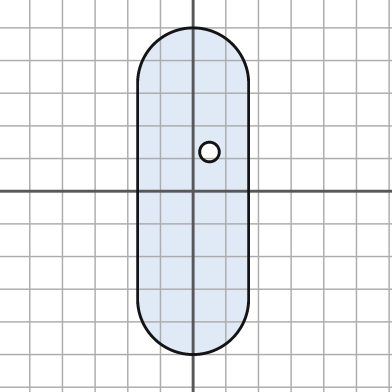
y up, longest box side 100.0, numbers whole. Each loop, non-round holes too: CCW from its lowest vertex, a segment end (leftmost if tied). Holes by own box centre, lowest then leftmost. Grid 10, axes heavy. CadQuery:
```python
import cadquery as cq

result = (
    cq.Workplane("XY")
    .moveTo(-17.0, -33.0)
    .threePointArc((0.0, -50.0), (17.0, -33.0))
    .lineTo(17.0, 33.0)
    .threePointArc((0.0, 50.0), (-17.0, 33.0))
    .close()
    .moveTo(5.0, 12.0)
    .circle(3.0)
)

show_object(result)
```